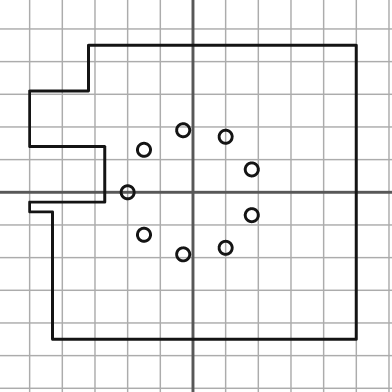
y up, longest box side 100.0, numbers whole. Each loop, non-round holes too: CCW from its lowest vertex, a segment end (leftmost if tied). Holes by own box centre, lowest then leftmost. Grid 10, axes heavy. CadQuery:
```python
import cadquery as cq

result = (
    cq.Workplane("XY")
    .moveTo(-43.0, -45.0)
    .lineTo(50.0, -45.0)
    .lineTo(50.0, 45.0)
    .lineTo(-32.0, 45.0)
    .lineTo(-32.0, 31.0)
    .lineTo(-50.0, 31.0)
    .lineTo(-50.0, 14.0)
    .lineTo(-27.0, 14.0)
    .lineTo(-27.0, -3.0)
    .lineTo(-50.0, -3.0)
    .lineTo(-50.0, -6.0)
    .lineTo(-43.0, -6.0)
    .close()
    .moveTo(-3.0, -19.0)
    .circle(2.0)
    .moveTo(10.0, -17.0)
    .circle(2.0)
    .moveTo(-15.0, -13.0)
    .circle(2.0)
    .moveTo(18.0, -7.0)
    .circle(2.0)
    .moveTo(-20.0, 0.0)
    .circle(2.0)
    .moveTo(18.0, 7.0)
    .circle(2.0)
    .moveTo(-15.0, 13.0)
    .circle(2.0)
    .moveTo(10.0, 17.0)
    .circle(2.0)
    .moveTo(-3.0, 19.0)
    .circle(2.0)
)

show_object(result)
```